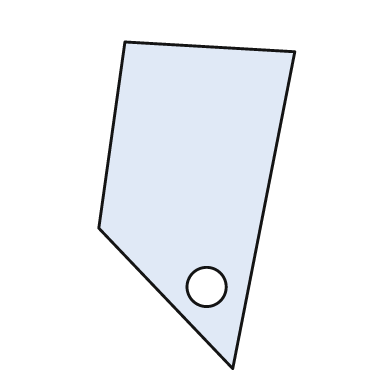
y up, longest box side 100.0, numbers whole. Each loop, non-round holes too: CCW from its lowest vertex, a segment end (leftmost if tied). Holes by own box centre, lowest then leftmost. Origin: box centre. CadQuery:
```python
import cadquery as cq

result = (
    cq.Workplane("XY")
    .moveTo(11.0, -50.0)
    .lineTo(30.0, 47.0)
    .lineTo(-22.0, 50.0)
    .lineTo(-30.0, -7.0)
    .close()
    .moveTo(3.0, -25.0)
    .circle(6.0)
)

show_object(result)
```